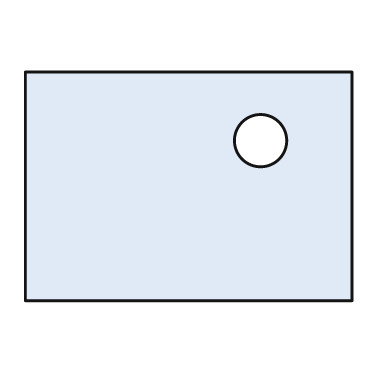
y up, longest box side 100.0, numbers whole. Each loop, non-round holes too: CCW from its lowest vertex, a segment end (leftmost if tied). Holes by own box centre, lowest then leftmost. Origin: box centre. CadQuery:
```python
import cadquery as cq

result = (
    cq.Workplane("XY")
    .moveTo(-50.0, -35.0)
    .lineTo(50.0, -35.0)
    .lineTo(50.0, 35.0)
    .lineTo(-50.0, 35.0)
    .close()
    .moveTo(22.0, 14.0)
    .circle(8.0)
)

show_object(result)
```